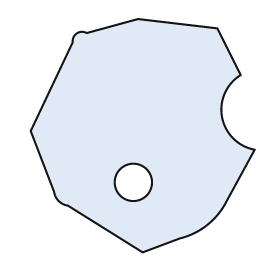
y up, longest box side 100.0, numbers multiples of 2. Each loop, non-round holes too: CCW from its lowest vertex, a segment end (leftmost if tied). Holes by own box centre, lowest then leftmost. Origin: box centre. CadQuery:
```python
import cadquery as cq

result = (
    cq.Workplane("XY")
    .moveTo(0.0, -50.0)
    .lineTo(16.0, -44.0)
    .threePointArc((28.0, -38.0), (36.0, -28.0))
    .lineTo(48.0, -6.0)
    .threePointArc((34.0, 8.0), (42.0, 26.0))
    .lineTo(32.0, 46.0)
    .lineTo(-2.0, 50.0)
    .lineTo(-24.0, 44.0)
    .threePointArc((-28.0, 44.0), (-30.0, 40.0))
    .lineTo(-48.0, 2.0)
    .lineTo(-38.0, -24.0)
    .threePointArc((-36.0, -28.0), (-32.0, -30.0))
    .close()
    .moveTo(-4.0, -20.0)
    .circle(8.0)
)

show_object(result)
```